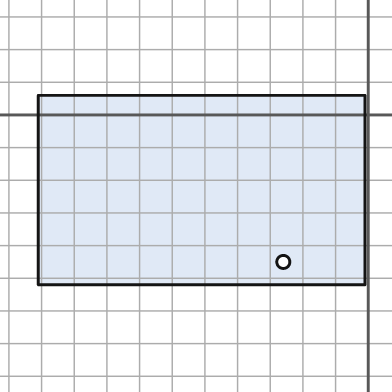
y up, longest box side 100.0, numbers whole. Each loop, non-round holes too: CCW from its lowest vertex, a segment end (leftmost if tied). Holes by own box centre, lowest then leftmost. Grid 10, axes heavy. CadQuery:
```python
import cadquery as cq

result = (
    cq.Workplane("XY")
    .moveTo(-101.0, -52.0)
    .lineTo(-1.0, -52.0)
    .lineTo(-1.0, 6.0)
    .lineTo(-101.0, 6.0)
    .close()
    .moveTo(-26.0, -45.0)
    .circle(2.0)
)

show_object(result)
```